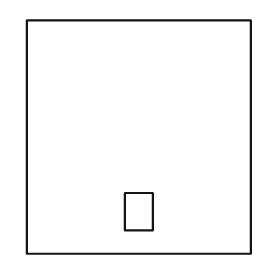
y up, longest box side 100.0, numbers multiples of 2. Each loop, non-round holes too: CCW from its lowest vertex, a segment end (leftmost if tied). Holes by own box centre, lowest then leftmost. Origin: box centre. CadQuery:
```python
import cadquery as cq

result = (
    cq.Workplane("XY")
    .moveTo(-48.0, -50.0)
    .lineTo(48.0, -50.0)
    .lineTo(48.0, 50.0)
    .lineTo(-48.0, 50.0)
    .close()
    .moveTo(-6.0, -40.0)
    .lineTo(6.0, -40.0)
    .lineTo(6.0, -24.0)
    .lineTo(-6.0, -24.0)
    .close()
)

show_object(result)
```